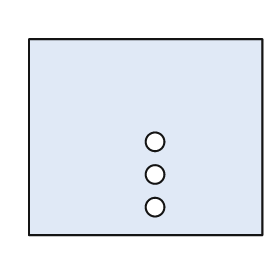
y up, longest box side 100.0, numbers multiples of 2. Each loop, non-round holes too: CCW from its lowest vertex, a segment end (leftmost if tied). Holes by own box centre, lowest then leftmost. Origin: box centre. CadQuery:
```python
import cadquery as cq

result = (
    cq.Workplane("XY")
    .moveTo(-50.0, -42.0)
    .lineTo(50.0, -42.0)
    .lineTo(50.0, 42.0)
    .lineTo(-50.0, 42.0)
    .close()
    .moveTo(4.0, -30.0)
    .circle(4.0)
    .moveTo(4.0, -16.0)
    .circle(4.0)
    .moveTo(4.0, -2.0)
    .circle(4.0)
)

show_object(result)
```